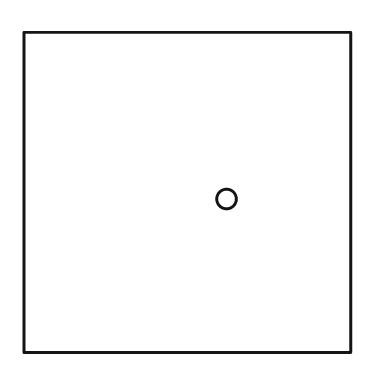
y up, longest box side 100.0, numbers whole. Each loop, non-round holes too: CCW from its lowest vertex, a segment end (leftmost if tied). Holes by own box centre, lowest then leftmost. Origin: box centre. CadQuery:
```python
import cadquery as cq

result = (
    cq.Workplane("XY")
    .moveTo(-50.0, -49.0)
    .lineTo(50.0, -49.0)
    .lineTo(50.0, 49.0)
    .lineTo(-50.0, 49.0)
    .close()
    .moveTo(12.0, -2.0)
    .circle(3.0)
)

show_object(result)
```